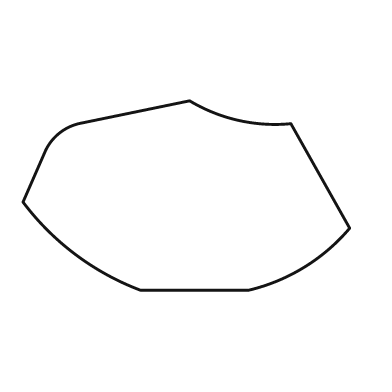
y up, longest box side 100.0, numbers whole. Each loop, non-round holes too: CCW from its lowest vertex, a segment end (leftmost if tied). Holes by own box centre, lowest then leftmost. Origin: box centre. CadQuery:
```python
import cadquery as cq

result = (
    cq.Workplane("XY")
    .moveTo(-14.0, -29.0)
    .lineTo(19.0, -29.0)
    .threePointArc((36.0, -22.0), (50.0, -10.0))
    .lineTo(32.0, 22.0)
    .threePointArc((16.0, 23.0), (1.0, 29.0))
    .lineTo(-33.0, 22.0)
    .threePointArc((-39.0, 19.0), (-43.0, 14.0))
    .lineTo(-50.0, -2.0)
    .threePointArc((-34.0, -18.0), (-14.0, -29.0))
    .close()
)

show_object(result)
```